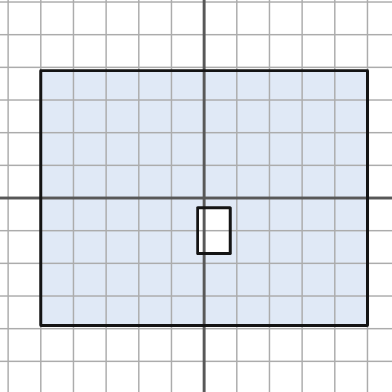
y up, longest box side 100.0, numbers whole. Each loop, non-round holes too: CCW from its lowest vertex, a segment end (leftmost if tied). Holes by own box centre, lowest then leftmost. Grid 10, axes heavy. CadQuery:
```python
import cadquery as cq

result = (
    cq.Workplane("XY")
    .moveTo(-50.0, -39.0)
    .lineTo(50.0, -39.0)
    .lineTo(50.0, 39.0)
    .lineTo(-50.0, 39.0)
    .close()
    .moveTo(-2.0, -17.0)
    .lineTo(8.0, -17.0)
    .lineTo(8.0, -3.0)
    .lineTo(-2.0, -3.0)
    .close()
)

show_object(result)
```